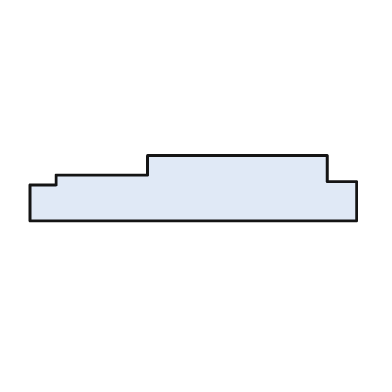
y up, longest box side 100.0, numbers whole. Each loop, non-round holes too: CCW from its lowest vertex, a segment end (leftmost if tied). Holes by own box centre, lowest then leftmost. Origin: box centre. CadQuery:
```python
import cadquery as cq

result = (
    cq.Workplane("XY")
    .moveTo(-50.0, -10.0)
    .lineTo(50.0, -10.0)
    .lineTo(50.0, 2.0)
    .lineTo(41.0, 2.0)
    .lineTo(41.0, 10.0)
    .lineTo(-14.0, 10.0)
    .lineTo(-14.0, 4.0)
    .lineTo(-42.0, 4.0)
    .lineTo(-42.0, 1.0)
    .lineTo(-50.0, 1.0)
    .close()
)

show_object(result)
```